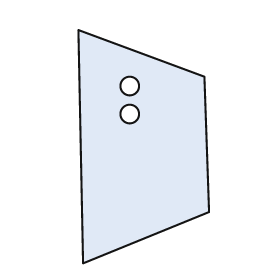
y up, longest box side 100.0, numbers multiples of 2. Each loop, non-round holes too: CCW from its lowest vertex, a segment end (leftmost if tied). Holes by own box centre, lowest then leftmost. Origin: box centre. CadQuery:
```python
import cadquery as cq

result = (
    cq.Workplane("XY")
    .moveTo(-26.0, -50.0)
    .lineTo(28.0, -28.0)
    .lineTo(26.0, 30.0)
    .lineTo(-28.0, 50.0)
    .close()
    .moveTo(-6.0, 14.0)
    .circle(4.0)
    .moveTo(-6.0, 26.0)
    .circle(4.0)
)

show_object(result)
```